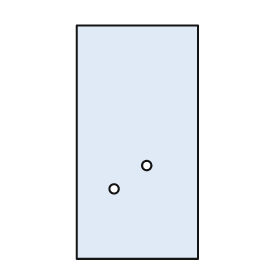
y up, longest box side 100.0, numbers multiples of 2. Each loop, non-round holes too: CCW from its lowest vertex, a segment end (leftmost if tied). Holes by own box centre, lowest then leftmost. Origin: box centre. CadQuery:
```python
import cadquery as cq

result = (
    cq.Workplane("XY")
    .moveTo(-26.0, -50.0)
    .lineTo(26.0, -50.0)
    .lineTo(26.0, 50.0)
    .lineTo(-26.0, 50.0)
    .close()
    .moveTo(-10.0, -20.0)
    .circle(2.0)
    .moveTo(4.0, -10.0)
    .circle(2.0)
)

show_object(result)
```